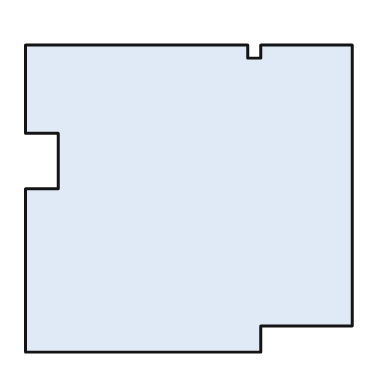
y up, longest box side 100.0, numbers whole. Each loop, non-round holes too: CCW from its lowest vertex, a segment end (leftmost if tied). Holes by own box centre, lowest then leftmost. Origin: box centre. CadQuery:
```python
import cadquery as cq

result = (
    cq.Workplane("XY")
    .moveTo(-50.0, -47.0)
    .lineTo(22.0, -47.0)
    .lineTo(22.0, -39.0)
    .lineTo(50.0, -39.0)
    .lineTo(50.0, 47.0)
    .lineTo(22.0, 47.0)
    .lineTo(22.0, 43.0)
    .lineTo(18.0, 43.0)
    .lineTo(18.0, 47.0)
    .lineTo(-50.0, 47.0)
    .lineTo(-50.0, 20.0)
    .lineTo(-40.0, 20.0)
    .lineTo(-40.0, 3.0)
    .lineTo(-50.0, 3.0)
    .close()
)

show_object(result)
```